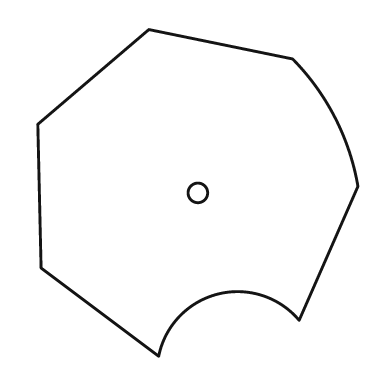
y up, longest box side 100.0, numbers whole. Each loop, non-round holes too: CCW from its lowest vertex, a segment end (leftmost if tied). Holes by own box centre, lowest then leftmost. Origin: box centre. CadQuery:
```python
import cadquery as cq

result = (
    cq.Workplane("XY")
    .moveTo(-12.0, -50.0)
    .threePointArc((6.0, -31.0), (31.0, -39.0))
    .lineTo(49.0, 2.0)
    .threePointArc((42.0, 23.0), (29.0, 41.0))
    .lineTo(-15.0, 50.0)
    .lineTo(-49.0, 21.0)
    .lineTo(-48.0, -23.0)
    .close()
    .moveTo(0.0, 0.0)
    .circle(3.0)
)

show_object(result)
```